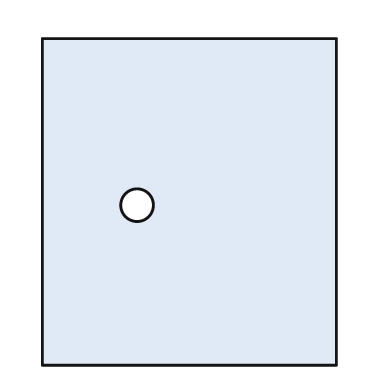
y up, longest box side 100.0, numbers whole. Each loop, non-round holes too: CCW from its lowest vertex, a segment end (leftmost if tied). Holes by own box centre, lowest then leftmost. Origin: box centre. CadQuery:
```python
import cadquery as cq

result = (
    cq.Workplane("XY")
    .moveTo(-45.0, -50.0)
    .lineTo(45.0, -50.0)
    .lineTo(45.0, 50.0)
    .lineTo(-45.0, 50.0)
    .close()
    .moveTo(-16.0, -1.0)
    .circle(5.0)
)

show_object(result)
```